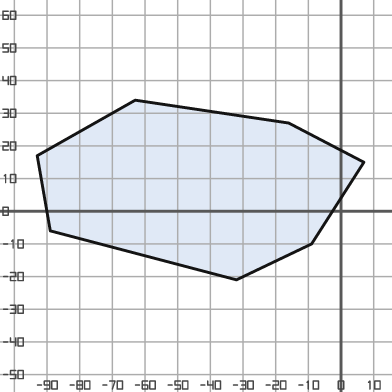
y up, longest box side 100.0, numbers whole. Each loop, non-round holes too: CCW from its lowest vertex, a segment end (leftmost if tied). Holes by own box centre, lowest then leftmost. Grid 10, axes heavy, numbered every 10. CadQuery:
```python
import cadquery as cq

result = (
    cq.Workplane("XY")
    .moveTo(-32.0, -21.0)
    .lineTo(-9.0, -10.0)
    .lineTo(7.0, 15.0)
    .lineTo(-16.0, 27.0)
    .lineTo(-63.0, 34.0)
    .lineTo(-93.0, 17.0)
    .lineTo(-89.0, -6.0)
    .close()
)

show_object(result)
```